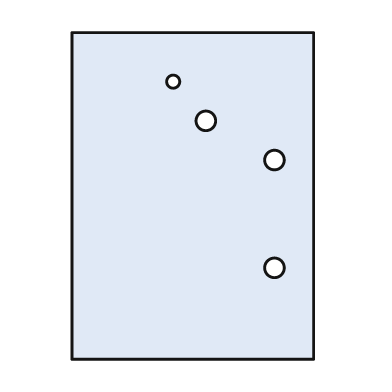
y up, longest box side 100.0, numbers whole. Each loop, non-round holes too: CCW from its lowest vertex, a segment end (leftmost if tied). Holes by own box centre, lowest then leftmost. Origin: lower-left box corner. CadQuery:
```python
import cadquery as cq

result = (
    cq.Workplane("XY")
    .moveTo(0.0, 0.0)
    .lineTo(74.0, 0.0)
    .lineTo(74.0, 100.0)
    .lineTo(0.0, 100.0)
    .close()
    .moveTo(62.0, 28.0)
    .circle(3.0)
    .moveTo(62.0, 61.0)
    .circle(3.0)
    .moveTo(41.0, 73.0)
    .circle(3.0)
    .moveTo(31.0, 85.0)
    .circle(2.0)
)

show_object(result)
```